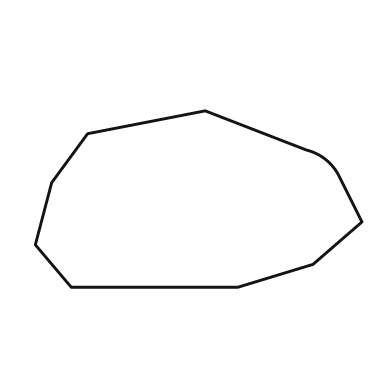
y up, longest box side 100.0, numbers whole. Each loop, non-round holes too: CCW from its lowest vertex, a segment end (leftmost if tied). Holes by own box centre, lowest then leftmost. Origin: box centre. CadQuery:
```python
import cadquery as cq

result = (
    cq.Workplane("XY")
    .moveTo(-39.0, -27.0)
    .lineTo(12.0, -27.0)
    .lineTo(35.0, -20.0)
    .lineTo(50.0, -7.0)
    .lineTo(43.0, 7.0)
    .threePointArc((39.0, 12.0), (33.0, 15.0))
    .lineTo(2.0, 27.0)
    .lineTo(-34.0, 20.0)
    .lineTo(-45.0, 5.0)
    .lineTo(-50.0, -14.0)
    .close()
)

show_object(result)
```